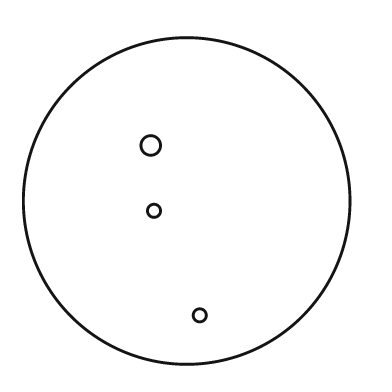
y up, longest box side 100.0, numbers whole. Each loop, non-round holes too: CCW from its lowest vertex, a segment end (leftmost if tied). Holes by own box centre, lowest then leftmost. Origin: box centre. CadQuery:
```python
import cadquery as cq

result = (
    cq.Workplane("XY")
    .moveTo(0.0, 0.0)
    .circle(50.0)
    .moveTo(4.0, -35.0)
    .circle(2.0)
    .moveTo(-10.0, -3.0)
    .circle(2.0)
    .moveTo(-11.0, 17.0)
    .circle(3.0)
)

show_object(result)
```